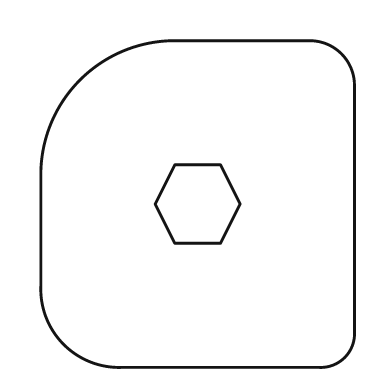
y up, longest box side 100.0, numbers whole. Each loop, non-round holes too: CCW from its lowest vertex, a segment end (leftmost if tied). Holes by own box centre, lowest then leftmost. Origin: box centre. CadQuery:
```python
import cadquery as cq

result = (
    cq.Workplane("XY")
    .moveTo(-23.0, -50.0)
    .lineTo(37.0, -50.0)
    .threePointArc((45.0, -47.0), (48.0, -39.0))
    .lineTo(48.0, 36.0)
    .threePointArc((44.0, 46.0), (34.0, 50.0))
    .lineTo(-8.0, 50.0)
    .threePointArc((-36.0, 38.0), (-48.0, 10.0))
    .lineTo(-48.0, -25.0)
    .threePointArc((-41.0, -43.0), (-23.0, -50.0))
    .close()
    .moveTo(-7.0, -12.0)
    .lineTo(7.0, -12.0)
    .lineTo(13.0, 0.0)
    .lineTo(7.0, 12.0)
    .lineTo(-7.0, 12.0)
    .lineTo(-13.0, 0.0)
    .close()
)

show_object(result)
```